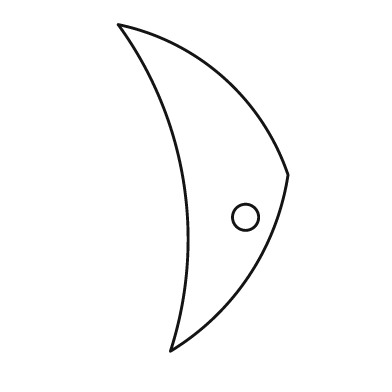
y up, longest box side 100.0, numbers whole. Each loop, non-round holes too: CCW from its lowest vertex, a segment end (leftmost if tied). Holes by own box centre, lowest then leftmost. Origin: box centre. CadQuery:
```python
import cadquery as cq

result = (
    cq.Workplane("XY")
    .moveTo(-10.0, -50.0)
    .threePointArc((14.0, -27.0), (26.0, 4.0))
    .threePointArc((6.0, 34.0), (-26.0, 50.0))
    .threePointArc((-6.0, 2.0), (-10.0, -50.0))
    .close()
    .moveTo(13.0, -9.0)
    .circle(4.0)
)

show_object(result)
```